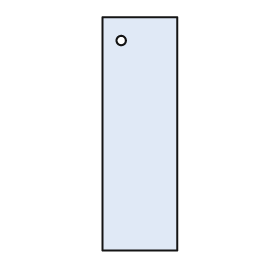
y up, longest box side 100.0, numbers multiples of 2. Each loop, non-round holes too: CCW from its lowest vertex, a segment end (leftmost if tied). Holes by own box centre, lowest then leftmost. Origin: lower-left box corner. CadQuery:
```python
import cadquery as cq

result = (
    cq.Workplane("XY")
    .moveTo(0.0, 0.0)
    .lineTo(32.0, 0.0)
    .lineTo(32.0, 100.0)
    .lineTo(0.0, 100.0)
    .close()
    .moveTo(8.0, 90.0)
    .circle(2.0)
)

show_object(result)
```